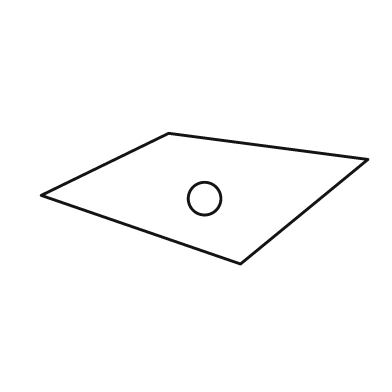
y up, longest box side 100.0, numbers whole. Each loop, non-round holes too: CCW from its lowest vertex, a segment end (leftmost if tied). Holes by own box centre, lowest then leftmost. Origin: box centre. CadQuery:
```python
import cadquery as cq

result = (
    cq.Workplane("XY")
    .moveTo(11.0, -20.0)
    .lineTo(50.0, 12.0)
    .lineTo(-11.0, 20.0)
    .lineTo(-50.0, 1.0)
    .close()
    .moveTo(0.0, 0.0)
    .circle(5.0)
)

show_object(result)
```